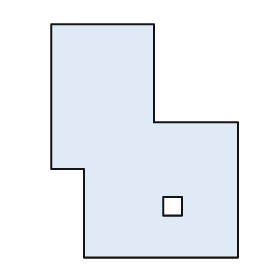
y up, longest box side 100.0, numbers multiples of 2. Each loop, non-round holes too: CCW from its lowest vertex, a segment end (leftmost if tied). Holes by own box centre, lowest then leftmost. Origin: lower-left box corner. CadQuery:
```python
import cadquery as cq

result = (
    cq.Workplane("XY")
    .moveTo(14.0, 0.0)
    .lineTo(80.0, 0.0)
    .lineTo(80.0, 58.0)
    .lineTo(44.0, 58.0)
    .lineTo(44.0, 100.0)
    .lineTo(0.0, 100.0)
    .lineTo(0.0, 38.0)
    .lineTo(14.0, 38.0)
    .close()
    .moveTo(48.0, 18.0)
    .lineTo(56.0, 18.0)
    .lineTo(56.0, 26.0)
    .lineTo(48.0, 26.0)
    .close()
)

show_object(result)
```